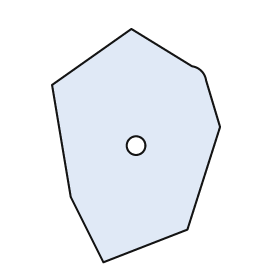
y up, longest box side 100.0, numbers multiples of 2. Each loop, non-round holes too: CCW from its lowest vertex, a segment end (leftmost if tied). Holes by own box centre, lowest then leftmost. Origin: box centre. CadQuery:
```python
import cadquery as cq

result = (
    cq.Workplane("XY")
    .moveTo(-14.0, -50.0)
    .lineTo(22.0, -36.0)
    .lineTo(36.0, 8.0)
    .lineTo(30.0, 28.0)
    .threePointArc((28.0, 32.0), (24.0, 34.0))
    .lineTo(-2.0, 50.0)
    .lineTo(-36.0, 26.0)
    .lineTo(-28.0, -22.0)
    .close()
    .moveTo(0.0, 0.0)
    .circle(4.0)
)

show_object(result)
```